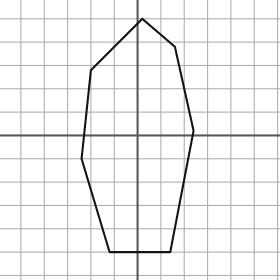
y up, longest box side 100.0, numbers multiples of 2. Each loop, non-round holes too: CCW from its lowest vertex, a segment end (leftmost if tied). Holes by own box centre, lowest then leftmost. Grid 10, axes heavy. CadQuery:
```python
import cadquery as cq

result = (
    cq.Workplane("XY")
    .moveTo(-12.0, -50.0)
    .lineTo(14.0, -50.0)
    .lineTo(24.0, 2.0)
    .lineTo(16.0, 38.0)
    .lineTo(2.0, 50.0)
    .lineTo(-20.0, 28.0)
    .lineTo(-24.0, -10.0)
    .close()
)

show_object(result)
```